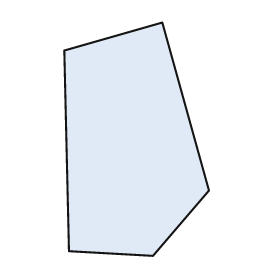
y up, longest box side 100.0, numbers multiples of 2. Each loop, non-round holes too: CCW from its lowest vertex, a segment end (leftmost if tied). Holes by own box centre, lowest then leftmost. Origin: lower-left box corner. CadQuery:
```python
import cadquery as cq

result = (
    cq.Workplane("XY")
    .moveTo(38.0, 0.0)
    .lineTo(62.0, 28.0)
    .lineTo(42.0, 100.0)
    .lineTo(0.0, 88.0)
    .lineTo(2.0, 2.0)
    .close()
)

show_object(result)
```